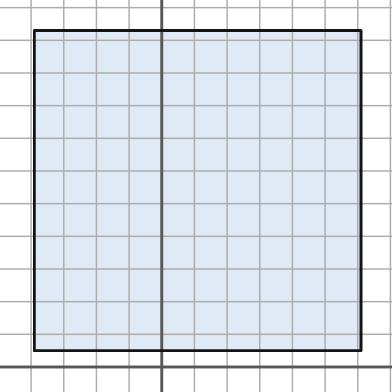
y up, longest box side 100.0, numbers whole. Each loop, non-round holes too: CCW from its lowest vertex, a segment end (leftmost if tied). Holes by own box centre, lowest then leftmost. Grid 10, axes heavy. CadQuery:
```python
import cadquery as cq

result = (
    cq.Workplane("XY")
    .moveTo(-39.0, 5.0)
    .lineTo(61.0, 5.0)
    .lineTo(61.0, 103.0)
    .lineTo(-39.0, 103.0)
    .close()
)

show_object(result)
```